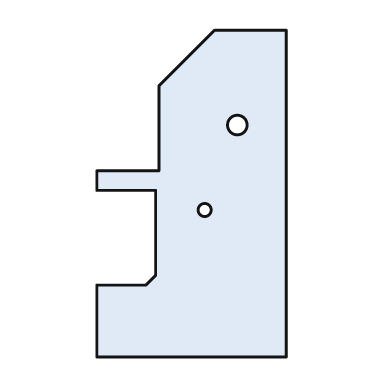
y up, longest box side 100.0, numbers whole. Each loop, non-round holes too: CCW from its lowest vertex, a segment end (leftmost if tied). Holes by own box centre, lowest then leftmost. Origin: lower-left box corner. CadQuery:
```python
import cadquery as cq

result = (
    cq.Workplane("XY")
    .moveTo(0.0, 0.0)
    .lineTo(58.0, 0.0)
    .lineTo(58.0, 100.0)
    .lineTo(36.0, 100.0)
    .lineTo(19.0, 83.0)
    .lineTo(19.0, 57.0)
    .lineTo(0.0, 57.0)
    .lineTo(0.0, 51.0)
    .lineTo(18.0, 51.0)
    .lineTo(18.0, 25.0)
    .lineTo(15.0, 22.0)
    .lineTo(0.0, 22.0)
    .close()
    .moveTo(33.0, 45.0)
    .circle(2.0)
    .moveTo(43.0, 71.0)
    .circle(3.0)
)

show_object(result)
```